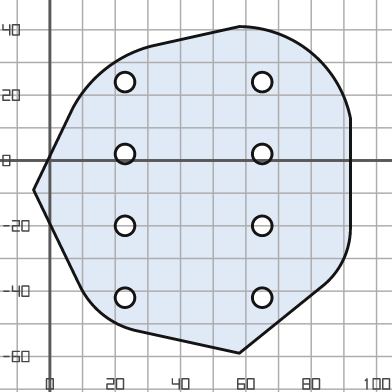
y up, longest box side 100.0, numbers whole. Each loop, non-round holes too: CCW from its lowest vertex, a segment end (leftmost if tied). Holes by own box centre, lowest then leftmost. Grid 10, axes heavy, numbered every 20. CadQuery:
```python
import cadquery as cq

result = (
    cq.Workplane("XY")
    .moveTo(58.0, -59.0)
    .lineTo(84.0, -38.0)
    .threePointArc((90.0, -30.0), (92.0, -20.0))
    .lineTo(92.0, 13.0)
    .threePointArc((80.0, 33.0), (58.0, 41.0))
    .lineTo(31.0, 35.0)
    .threePointArc((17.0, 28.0), (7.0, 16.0))
    .lineTo(-5.0, -9.0)
    .lineTo(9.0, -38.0)
    .threePointArc((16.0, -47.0), (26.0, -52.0))
    .close()
    .moveTo(23.0, -42.0)
    .circle(3.0)
    .moveTo(65.0, -42.0)
    .circle(3.0)
    .moveTo(23.0, -20.0)
    .circle(3.0)
    .moveTo(65.0, -20.0)
    .circle(3.0)
    .moveTo(23.0, 2.0)
    .circle(3.0)
    .moveTo(65.0, 2.0)
    .circle(3.0)
    .moveTo(23.0, 24.0)
    .circle(3.0)
    .moveTo(65.0, 24.0)
    .circle(3.0)
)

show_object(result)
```